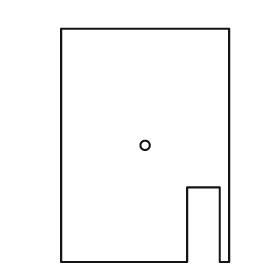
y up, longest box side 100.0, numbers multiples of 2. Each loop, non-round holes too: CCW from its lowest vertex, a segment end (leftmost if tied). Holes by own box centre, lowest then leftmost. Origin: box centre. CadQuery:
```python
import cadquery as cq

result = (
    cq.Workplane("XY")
    .moveTo(-36.0, -50.0)
    .lineTo(18.0, -50.0)
    .lineTo(18.0, -18.0)
    .lineTo(32.0, -18.0)
    .lineTo(32.0, -50.0)
    .lineTo(36.0, -50.0)
    .lineTo(36.0, 50.0)
    .lineTo(-36.0, 50.0)
    .close()
    .moveTo(0.0, 0.0)
    .circle(2.0)
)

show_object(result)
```